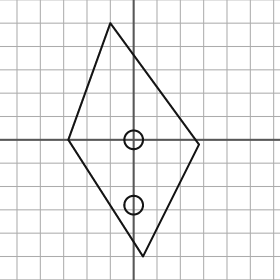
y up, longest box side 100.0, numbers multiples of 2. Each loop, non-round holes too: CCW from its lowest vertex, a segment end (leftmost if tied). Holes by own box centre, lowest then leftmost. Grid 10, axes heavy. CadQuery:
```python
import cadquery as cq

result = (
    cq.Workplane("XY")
    .moveTo(4.0, -50.0)
    .lineTo(28.0, -2.0)
    .lineTo(-10.0, 50.0)
    .lineTo(-28.0, 0.0)
    .close()
    .moveTo(0.0, -28.0)
    .circle(4.0)
    .moveTo(0.0, 0.0)
    .circle(4.0)
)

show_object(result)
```